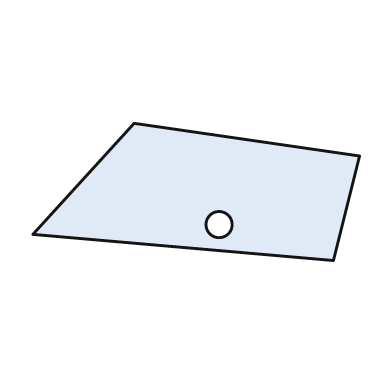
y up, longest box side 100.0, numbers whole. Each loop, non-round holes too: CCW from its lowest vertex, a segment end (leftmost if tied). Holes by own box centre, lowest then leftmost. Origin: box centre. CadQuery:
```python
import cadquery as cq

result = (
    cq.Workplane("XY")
    .moveTo(42.0, -21.0)
    .lineTo(50.0, 11.0)
    .lineTo(-19.0, 21.0)
    .lineTo(-50.0, -13.0)
    .close()
    .moveTo(7.0, -10.0)
    .circle(4.0)
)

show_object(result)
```